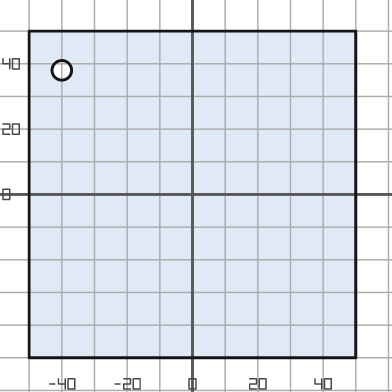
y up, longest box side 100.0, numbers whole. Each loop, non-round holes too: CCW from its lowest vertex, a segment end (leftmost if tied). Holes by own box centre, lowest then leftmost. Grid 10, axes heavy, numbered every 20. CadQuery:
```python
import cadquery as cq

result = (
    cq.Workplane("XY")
    .moveTo(-50.0, -50.0)
    .lineTo(50.0, -50.0)
    .lineTo(50.0, 50.0)
    .lineTo(-50.0, 50.0)
    .close()
    .moveTo(-40.0, 38.0)
    .circle(3.0)
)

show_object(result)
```